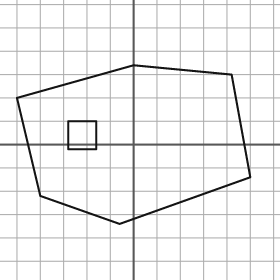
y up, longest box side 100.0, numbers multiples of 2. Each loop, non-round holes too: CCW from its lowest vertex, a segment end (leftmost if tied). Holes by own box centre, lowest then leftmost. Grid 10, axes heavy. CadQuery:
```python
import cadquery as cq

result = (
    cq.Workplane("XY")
    .moveTo(-6.0, -34.0)
    .lineTo(50.0, -14.0)
    .lineTo(42.0, 30.0)
    .lineTo(0.0, 34.0)
    .lineTo(-50.0, 20.0)
    .lineTo(-40.0, -22.0)
    .close()
    .moveTo(-28.0, -2.0)
    .lineTo(-16.0, -2.0)
    .lineTo(-16.0, 10.0)
    .lineTo(-28.0, 10.0)
    .close()
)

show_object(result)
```